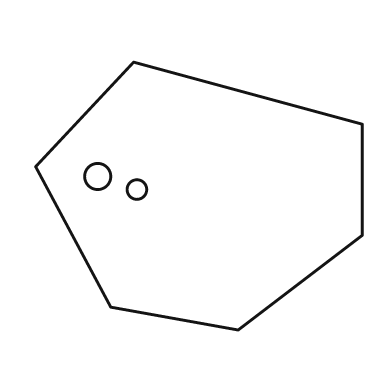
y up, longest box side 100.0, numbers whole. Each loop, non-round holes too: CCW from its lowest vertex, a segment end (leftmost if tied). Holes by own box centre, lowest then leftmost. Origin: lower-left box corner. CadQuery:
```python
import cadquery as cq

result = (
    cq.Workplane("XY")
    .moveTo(62.0, 0.0)
    .lineTo(100.0, 29.0)
    .lineTo(100.0, 63.0)
    .lineTo(30.0, 82.0)
    .lineTo(0.0, 50.0)
    .lineTo(23.0, 7.0)
    .close()
    .moveTo(31.0, 43.0)
    .circle(3.0)
    .moveTo(19.0, 47.0)
    .circle(4.0)
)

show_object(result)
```